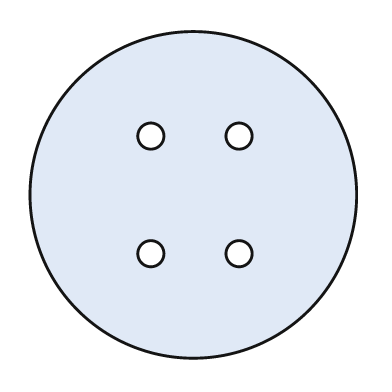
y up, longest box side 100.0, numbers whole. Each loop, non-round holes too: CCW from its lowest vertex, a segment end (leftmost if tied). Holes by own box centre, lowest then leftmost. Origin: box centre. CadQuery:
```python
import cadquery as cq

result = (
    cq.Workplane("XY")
    .moveTo(0.0, 0.0)
    .circle(50.0)
    .moveTo(-13.0, -18.0)
    .circle(4.0)
    .moveTo(14.0, -18.0)
    .circle(4.0)
    .moveTo(-13.0, 18.0)
    .circle(4.0)
    .moveTo(14.0, 18.0)
    .circle(4.0)
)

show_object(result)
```